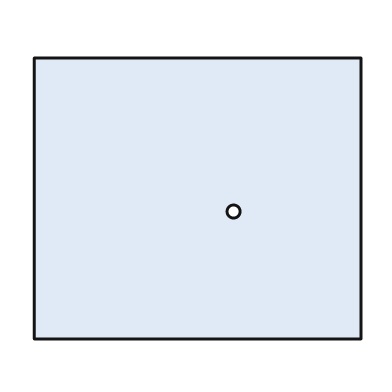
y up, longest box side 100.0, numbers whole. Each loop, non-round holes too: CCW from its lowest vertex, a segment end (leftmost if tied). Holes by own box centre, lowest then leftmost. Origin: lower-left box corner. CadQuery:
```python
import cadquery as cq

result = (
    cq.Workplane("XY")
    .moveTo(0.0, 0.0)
    .lineTo(100.0, 0.0)
    .lineTo(100.0, 86.0)
    .lineTo(0.0, 86.0)
    .close()
    .moveTo(61.0, 39.0)
    .circle(2.0)
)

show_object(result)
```